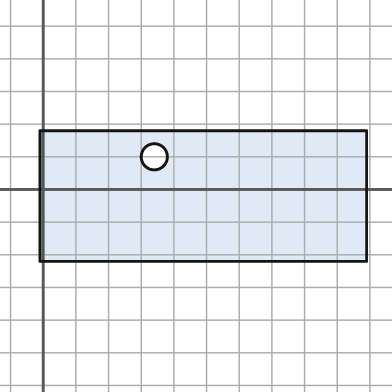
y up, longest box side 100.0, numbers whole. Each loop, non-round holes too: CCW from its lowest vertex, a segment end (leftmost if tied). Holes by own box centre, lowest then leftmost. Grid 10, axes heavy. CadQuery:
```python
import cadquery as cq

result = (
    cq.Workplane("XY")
    .moveTo(-1.0, -22.0)
    .lineTo(99.0, -22.0)
    .lineTo(99.0, 18.0)
    .lineTo(-1.0, 18.0)
    .close()
    .moveTo(34.0, 10.0)
    .circle(4.0)
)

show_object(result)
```